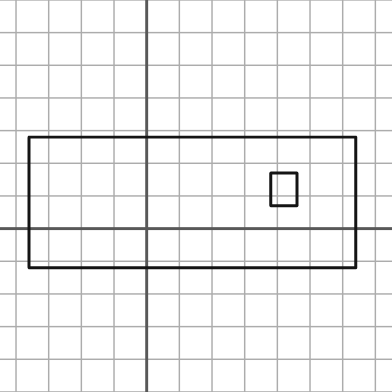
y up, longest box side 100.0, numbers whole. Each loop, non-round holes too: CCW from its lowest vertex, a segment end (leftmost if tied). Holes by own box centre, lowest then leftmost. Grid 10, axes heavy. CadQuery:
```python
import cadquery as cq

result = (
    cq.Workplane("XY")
    .moveTo(-36.0, -12.0)
    .lineTo(64.0, -12.0)
    .lineTo(64.0, 28.0)
    .lineTo(-36.0, 28.0)
    .close()
    .moveTo(38.0, 7.0)
    .lineTo(46.0, 7.0)
    .lineTo(46.0, 17.0)
    .lineTo(38.0, 17.0)
    .close()
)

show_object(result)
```